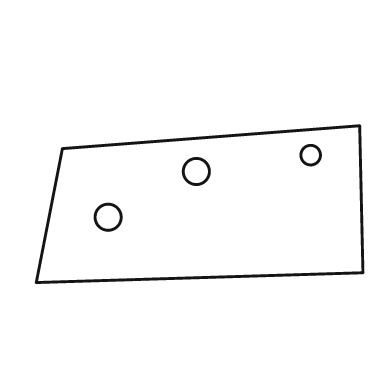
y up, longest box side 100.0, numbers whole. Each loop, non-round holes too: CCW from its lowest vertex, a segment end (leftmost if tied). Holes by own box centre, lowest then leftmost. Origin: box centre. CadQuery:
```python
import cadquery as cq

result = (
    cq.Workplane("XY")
    .moveTo(-50.0, -24.0)
    .lineTo(50.0, -21.0)
    .lineTo(49.0, 24.0)
    .lineTo(-42.0, 17.0)
    .close()
    .moveTo(-28.0, -4.0)
    .circle(4.0)
    .moveTo(-1.0, 10.0)
    .circle(4.0)
    .moveTo(34.0, 15.0)
    .circle(3.0)
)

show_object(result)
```